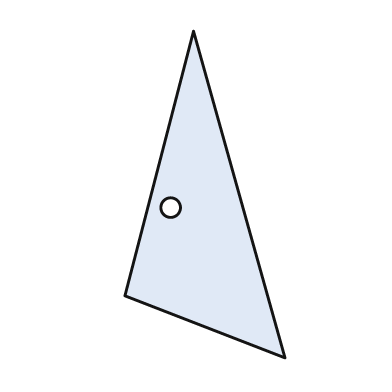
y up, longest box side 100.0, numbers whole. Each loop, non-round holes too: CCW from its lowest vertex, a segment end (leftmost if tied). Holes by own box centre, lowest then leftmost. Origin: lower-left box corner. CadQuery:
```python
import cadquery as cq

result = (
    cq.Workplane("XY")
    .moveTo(49.0, 0.0)
    .lineTo(21.0, 100.0)
    .lineTo(0.0, 19.0)
    .close()
    .moveTo(14.0, 46.0)
    .circle(3.0)
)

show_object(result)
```